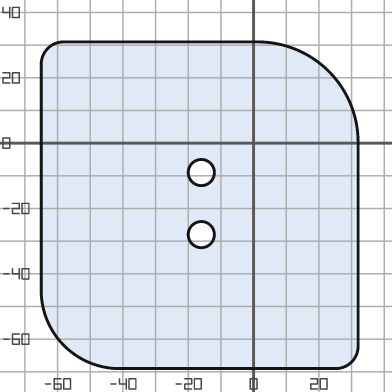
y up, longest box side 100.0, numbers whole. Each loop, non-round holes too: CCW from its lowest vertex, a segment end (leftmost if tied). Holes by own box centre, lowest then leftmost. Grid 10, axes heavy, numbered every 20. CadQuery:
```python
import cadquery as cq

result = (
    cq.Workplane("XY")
    .moveTo(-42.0, -69.0)
    .lineTo(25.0, -69.0)
    .threePointArc((30.0, -67.0), (32.0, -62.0))
    .lineTo(32.0, 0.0)
    .threePointArc((23.0, 22.0), (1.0, 31.0))
    .lineTo(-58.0, 31.0)
    .threePointArc((-63.0, 29.0), (-65.0, 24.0))
    .lineTo(-65.0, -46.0)
    .threePointArc((-58.0, -62.0), (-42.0, -69.0))
    .close()
    .moveTo(-16.0, -28.0)
    .circle(4.0)
    .moveTo(-16.0, -9.0)
    .circle(4.0)
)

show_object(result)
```